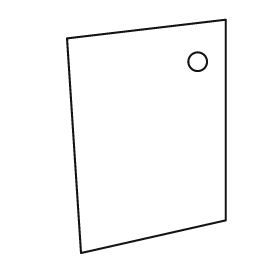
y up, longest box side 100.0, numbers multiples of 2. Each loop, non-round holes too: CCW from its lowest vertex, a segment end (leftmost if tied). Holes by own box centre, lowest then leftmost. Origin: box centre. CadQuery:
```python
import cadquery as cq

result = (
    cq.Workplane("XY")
    .moveTo(-28.0, -50.0)
    .lineTo(34.0, -36.0)
    .lineTo(34.0, 50.0)
    .lineTo(-34.0, 42.0)
    .close()
    .moveTo(22.0, 32.0)
    .circle(4.0)
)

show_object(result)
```